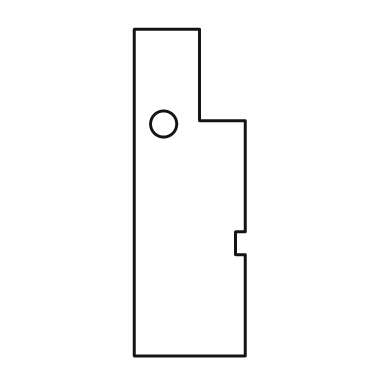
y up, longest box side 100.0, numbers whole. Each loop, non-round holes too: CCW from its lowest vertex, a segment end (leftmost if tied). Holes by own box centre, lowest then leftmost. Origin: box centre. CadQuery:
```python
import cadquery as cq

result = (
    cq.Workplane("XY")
    .moveTo(-17.0, -50.0)
    .lineTo(17.0, -50.0)
    .lineTo(17.0, -19.0)
    .lineTo(14.0, -19.0)
    .lineTo(14.0, -12.0)
    .lineTo(17.0, -12.0)
    .lineTo(17.0, 22.0)
    .lineTo(3.0, 22.0)
    .lineTo(3.0, 50.0)
    .lineTo(-17.0, 50.0)
    .close()
    .moveTo(-8.0, 21.0)
    .circle(4.0)
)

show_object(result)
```